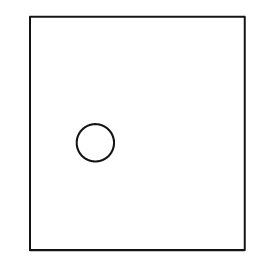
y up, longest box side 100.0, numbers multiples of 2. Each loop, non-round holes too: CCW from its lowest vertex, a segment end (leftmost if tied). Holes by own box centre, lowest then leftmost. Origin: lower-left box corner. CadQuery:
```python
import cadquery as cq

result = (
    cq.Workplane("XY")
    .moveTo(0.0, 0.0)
    .lineTo(92.0, 0.0)
    .lineTo(92.0, 100.0)
    .lineTo(0.0, 100.0)
    .close()
    .moveTo(28.0, 46.0)
    .circle(8.0)
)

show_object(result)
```